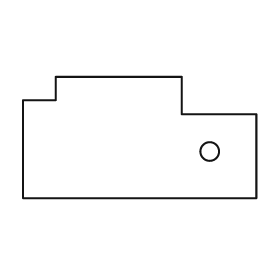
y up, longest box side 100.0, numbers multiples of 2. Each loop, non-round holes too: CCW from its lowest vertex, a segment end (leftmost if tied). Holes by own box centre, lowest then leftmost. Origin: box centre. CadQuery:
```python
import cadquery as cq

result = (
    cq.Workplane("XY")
    .moveTo(-50.0, -26.0)
    .lineTo(50.0, -26.0)
    .lineTo(50.0, 10.0)
    .lineTo(18.0, 10.0)
    .lineTo(18.0, 26.0)
    .lineTo(-36.0, 26.0)
    .lineTo(-36.0, 16.0)
    .lineTo(-50.0, 16.0)
    .close()
    .moveTo(30.0, -6.0)
    .circle(4.0)
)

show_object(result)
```